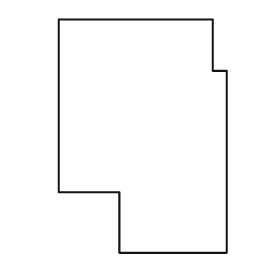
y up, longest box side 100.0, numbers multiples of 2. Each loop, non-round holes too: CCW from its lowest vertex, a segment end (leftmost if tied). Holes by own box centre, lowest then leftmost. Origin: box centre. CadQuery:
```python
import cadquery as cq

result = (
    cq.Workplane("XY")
    .moveTo(-10.0, -50.0)
    .lineTo(36.0, -50.0)
    .lineTo(36.0, 28.0)
    .lineTo(30.0, 28.0)
    .lineTo(30.0, 50.0)
    .lineTo(-36.0, 50.0)
    .lineTo(-36.0, -24.0)
    .lineTo(-10.0, -24.0)
    .close()
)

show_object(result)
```